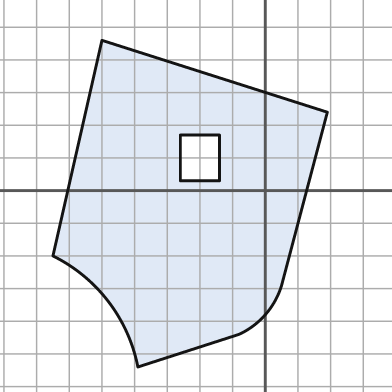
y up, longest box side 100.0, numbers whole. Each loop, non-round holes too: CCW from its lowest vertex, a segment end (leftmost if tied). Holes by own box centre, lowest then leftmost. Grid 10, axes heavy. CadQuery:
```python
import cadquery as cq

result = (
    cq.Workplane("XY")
    .moveTo(-39.0, -54.0)
    .lineTo(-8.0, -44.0)
    .threePointArc((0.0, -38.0), (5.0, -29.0))
    .lineTo(19.0, 24.0)
    .lineTo(-50.0, 46.0)
    .lineTo(-65.0, -20.0)
    .threePointArc((-48.0, -34.0), (-39.0, -54.0))
    .close()
    .moveTo(-26.0, 3.0)
    .lineTo(-14.0, 3.0)
    .lineTo(-14.0, 17.0)
    .lineTo(-26.0, 17.0)
    .close()
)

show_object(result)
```